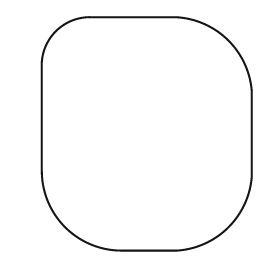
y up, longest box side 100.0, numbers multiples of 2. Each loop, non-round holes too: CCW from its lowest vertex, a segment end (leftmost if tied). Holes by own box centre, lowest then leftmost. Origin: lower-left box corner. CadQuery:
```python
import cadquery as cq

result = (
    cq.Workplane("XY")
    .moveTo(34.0, 0.0)
    .lineTo(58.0, 0.0)
    .threePointArc((80.0, 10.0), (90.0, 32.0))
    .lineTo(90.0, 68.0)
    .threePointArc((80.0, 90.0), (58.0, 100.0))
    .lineTo(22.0, 100.0)
    .threePointArc((6.0, 94.0), (0.0, 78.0))
    .lineTo(0.0, 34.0)
    .threePointArc((10.0, 10.0), (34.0, 0.0))
    .close()
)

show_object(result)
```